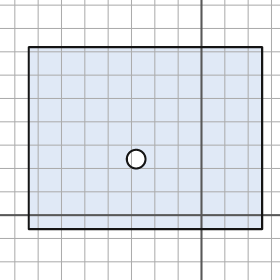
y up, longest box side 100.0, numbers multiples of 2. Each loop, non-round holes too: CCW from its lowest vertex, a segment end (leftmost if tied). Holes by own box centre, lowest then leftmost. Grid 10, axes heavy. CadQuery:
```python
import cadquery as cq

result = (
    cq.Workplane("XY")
    .moveTo(-74.0, -6.0)
    .lineTo(26.0, -6.0)
    .lineTo(26.0, 72.0)
    .lineTo(-74.0, 72.0)
    .close()
    .moveTo(-28.0, 24.0)
    .circle(4.0)
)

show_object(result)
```